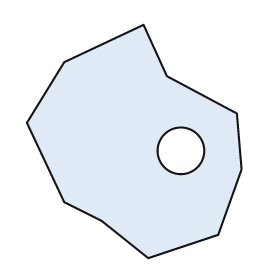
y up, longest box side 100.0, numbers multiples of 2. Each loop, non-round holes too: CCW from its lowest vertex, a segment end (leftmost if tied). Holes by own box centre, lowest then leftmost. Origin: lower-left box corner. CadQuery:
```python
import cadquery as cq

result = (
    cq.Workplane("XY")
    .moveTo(52.0, 0.0)
    .lineTo(82.0, 10.0)
    .lineTo(92.0, 38.0)
    .lineTo(90.0, 62.0)
    .lineTo(60.0, 78.0)
    .lineTo(50.0, 100.0)
    .lineTo(16.0, 84.0)
    .lineTo(0.0, 58.0)
    .lineTo(16.0, 24.0)
    .lineTo(32.0, 16.0)
    .close()
    .moveTo(66.0, 46.0)
    .circle(10.0)
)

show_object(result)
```